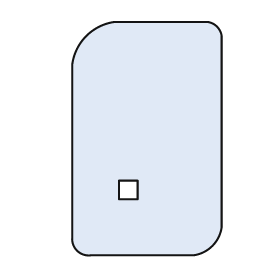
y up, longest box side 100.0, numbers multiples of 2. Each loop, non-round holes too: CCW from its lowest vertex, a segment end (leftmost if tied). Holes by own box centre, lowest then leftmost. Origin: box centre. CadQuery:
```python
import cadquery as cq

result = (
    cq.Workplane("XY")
    .moveTo(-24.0, -50.0)
    .lineTo(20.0, -50.0)
    .threePointArc((28.0, -46.0), (32.0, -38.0))
    .lineTo(32.0, 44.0)
    .threePointArc((30.0, 48.0), (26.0, 50.0))
    .lineTo(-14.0, 50.0)
    .threePointArc((-26.0, 44.0), (-32.0, 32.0))
    .lineTo(-32.0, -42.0)
    .threePointArc((-30.0, -48.0), (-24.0, -50.0))
    .close()
    .moveTo(-12.0, -26.0)
    .lineTo(-4.0, -26.0)
    .lineTo(-4.0, -18.0)
    .lineTo(-12.0, -18.0)
    .close()
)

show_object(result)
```